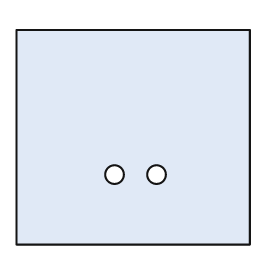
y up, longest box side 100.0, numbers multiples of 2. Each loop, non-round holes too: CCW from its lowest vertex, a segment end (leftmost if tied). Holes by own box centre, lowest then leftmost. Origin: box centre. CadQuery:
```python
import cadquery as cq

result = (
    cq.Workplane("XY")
    .moveTo(-50.0, -46.0)
    .lineTo(50.0, -46.0)
    .lineTo(50.0, 46.0)
    .lineTo(-50.0, 46.0)
    .close()
    .moveTo(-8.0, -16.0)
    .circle(4.0)
    .moveTo(10.0, -16.0)
    .circle(4.0)
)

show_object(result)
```